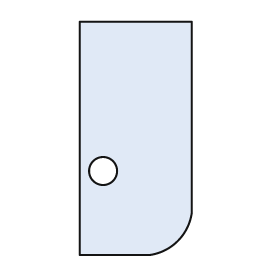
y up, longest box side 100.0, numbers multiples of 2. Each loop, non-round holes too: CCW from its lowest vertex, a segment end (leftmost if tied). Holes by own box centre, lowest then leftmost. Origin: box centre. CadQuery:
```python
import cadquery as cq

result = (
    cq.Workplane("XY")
    .moveTo(-24.0, -50.0)
    .lineTo(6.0, -50.0)
    .threePointArc((18.0, -44.0), (24.0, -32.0))
    .lineTo(24.0, 50.0)
    .lineTo(-24.0, 50.0)
    .close()
    .moveTo(-14.0, -14.0)
    .circle(6.0)
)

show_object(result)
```